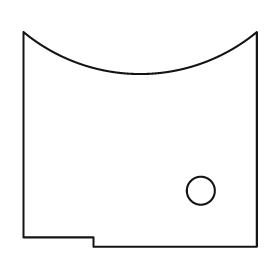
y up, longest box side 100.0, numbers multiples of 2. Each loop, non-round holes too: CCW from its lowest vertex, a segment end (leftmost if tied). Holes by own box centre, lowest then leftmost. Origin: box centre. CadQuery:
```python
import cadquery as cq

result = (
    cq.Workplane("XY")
    .moveTo(-20.0, -46.0)
    .lineTo(50.0, -46.0)
    .lineTo(50.0, 46.0)
    .threePointArc((0.0, 28.0), (-50.0, 46.0))
    .lineTo(-50.0, -42.0)
    .lineTo(-20.0, -42.0)
    .close()
    .moveTo(26.0, -22.0)
    .circle(6.0)
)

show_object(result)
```